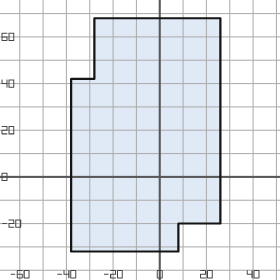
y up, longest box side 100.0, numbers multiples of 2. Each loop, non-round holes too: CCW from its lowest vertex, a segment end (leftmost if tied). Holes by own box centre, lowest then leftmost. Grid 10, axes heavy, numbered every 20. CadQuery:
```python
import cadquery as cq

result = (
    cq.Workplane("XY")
    .moveTo(-38.0, -32.0)
    .lineTo(8.0, -32.0)
    .lineTo(8.0, -20.0)
    .lineTo(26.0, -20.0)
    .lineTo(26.0, 68.0)
    .lineTo(-28.0, 68.0)
    .lineTo(-28.0, 42.0)
    .lineTo(-38.0, 42.0)
    .close()
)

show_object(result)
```